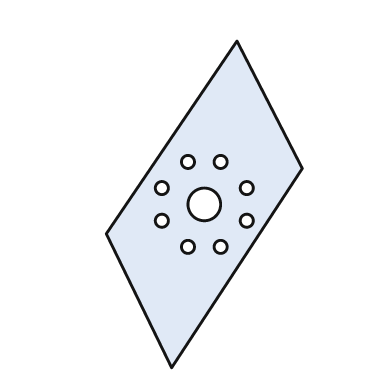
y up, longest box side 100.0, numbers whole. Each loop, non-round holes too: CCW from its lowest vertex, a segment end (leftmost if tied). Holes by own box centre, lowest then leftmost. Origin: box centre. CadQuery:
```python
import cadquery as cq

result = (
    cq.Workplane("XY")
    .moveTo(-10.0, -50.0)
    .lineTo(30.0, 11.0)
    .lineTo(10.0, 50.0)
    .lineTo(-30.0, -9.0)
    .close()
    .moveTo(-5.0, -13.0)
    .circle(2.0)
    .moveTo(5.0, -13.0)
    .circle(2.0)
    .moveTo(-13.0, -5.0)
    .circle(2.0)
    .moveTo(13.0, -5.0)
    .circle(2.0)
    .moveTo(0.0, 0.0)
    .circle(5.0)
    .moveTo(-13.0, 5.0)
    .circle(2.0)
    .moveTo(13.0, 5.0)
    .circle(2.0)
    .moveTo(-5.0, 13.0)
    .circle(2.0)
    .moveTo(5.0, 13.0)
    .circle(2.0)
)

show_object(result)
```